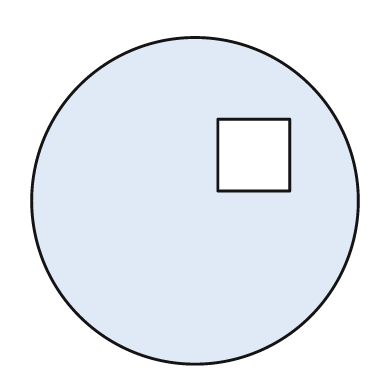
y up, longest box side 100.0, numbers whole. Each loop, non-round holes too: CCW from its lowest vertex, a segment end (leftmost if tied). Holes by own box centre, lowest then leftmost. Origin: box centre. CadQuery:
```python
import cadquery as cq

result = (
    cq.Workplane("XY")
    .moveTo(0.0, 0.0)
    .circle(50.0)
    .moveTo(7.0, 3.0)
    .lineTo(29.0, 3.0)
    .lineTo(29.0, 25.0)
    .lineTo(7.0, 25.0)
    .close()
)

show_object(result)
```